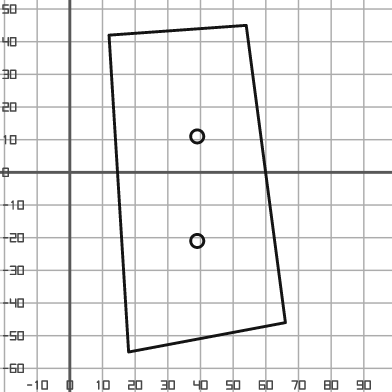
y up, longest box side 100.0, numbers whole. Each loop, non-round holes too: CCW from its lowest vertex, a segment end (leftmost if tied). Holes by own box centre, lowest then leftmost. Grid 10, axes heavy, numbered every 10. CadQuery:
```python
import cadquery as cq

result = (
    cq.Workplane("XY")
    .moveTo(18.0, -55.0)
    .lineTo(66.0, -46.0)
    .lineTo(54.0, 45.0)
    .lineTo(12.0, 42.0)
    .close()
    .moveTo(39.0, -21.0)
    .circle(2.0)
    .moveTo(39.0, 11.0)
    .circle(2.0)
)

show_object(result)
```